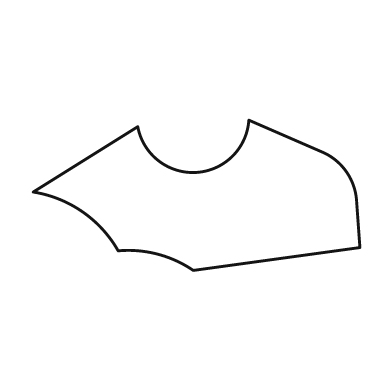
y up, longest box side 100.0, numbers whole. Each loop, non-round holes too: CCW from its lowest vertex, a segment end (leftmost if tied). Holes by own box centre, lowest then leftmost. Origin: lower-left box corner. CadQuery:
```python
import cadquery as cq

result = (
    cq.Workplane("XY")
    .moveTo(49.0, 0.0)
    .lineTo(100.0, 7.0)
    .lineTo(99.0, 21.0)
    .threePointArc((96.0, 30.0), (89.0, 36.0))
    .lineTo(66.0, 46.0)
    .threePointArc((50.0, 30.0), (32.0, 44.0))
    .lineTo(0.0, 24.0)
    .threePointArc((15.0, 18.0), (26.0, 6.0))
    .threePointArc((38.0, 5.0), (49.0, 0.0))
    .close()
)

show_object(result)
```